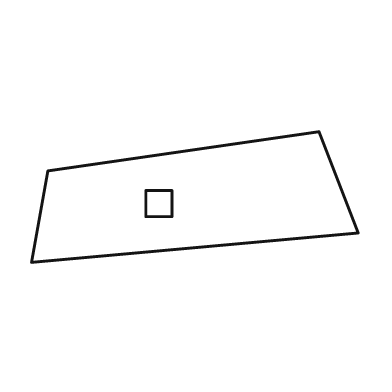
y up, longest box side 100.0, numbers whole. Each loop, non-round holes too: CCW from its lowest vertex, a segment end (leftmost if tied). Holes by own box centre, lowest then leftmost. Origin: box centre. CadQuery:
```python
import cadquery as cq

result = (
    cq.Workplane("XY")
    .moveTo(-50.0, -20.0)
    .lineTo(50.0, -11.0)
    .lineTo(38.0, 20.0)
    .lineTo(-45.0, 8.0)
    .close()
    .moveTo(-15.0, -6.0)
    .lineTo(-7.0, -6.0)
    .lineTo(-7.0, 2.0)
    .lineTo(-15.0, 2.0)
    .close()
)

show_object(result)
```